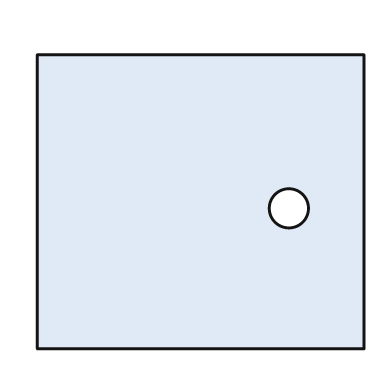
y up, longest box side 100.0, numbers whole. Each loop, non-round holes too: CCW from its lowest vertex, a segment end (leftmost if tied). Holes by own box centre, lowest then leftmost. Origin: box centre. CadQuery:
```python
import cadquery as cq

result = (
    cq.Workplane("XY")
    .moveTo(-50.0, -45.0)
    .lineTo(50.0, -45.0)
    .lineTo(50.0, 45.0)
    .lineTo(-50.0, 45.0)
    .close()
    .moveTo(27.0, -2.0)
    .circle(6.0)
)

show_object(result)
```